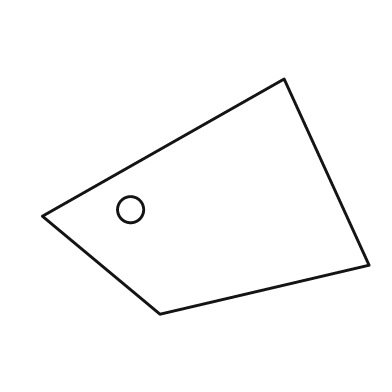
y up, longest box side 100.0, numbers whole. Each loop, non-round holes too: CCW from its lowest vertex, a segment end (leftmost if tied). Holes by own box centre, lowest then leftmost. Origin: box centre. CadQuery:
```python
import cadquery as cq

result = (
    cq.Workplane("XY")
    .moveTo(-14.0, -36.0)
    .lineTo(50.0, -21.0)
    .lineTo(24.0, 36.0)
    .lineTo(-50.0, -6.0)
    .close()
    .moveTo(-23.0, -4.0)
    .circle(4.0)
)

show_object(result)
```